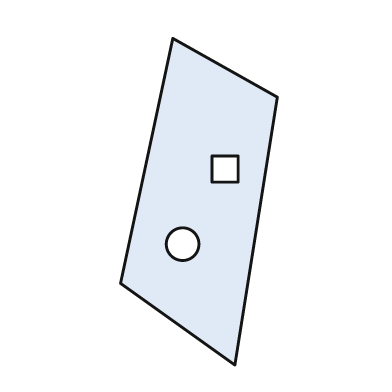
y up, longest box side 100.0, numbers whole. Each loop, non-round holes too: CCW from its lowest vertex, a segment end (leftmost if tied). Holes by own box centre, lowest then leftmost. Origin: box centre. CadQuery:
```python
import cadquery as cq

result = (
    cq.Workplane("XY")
    .moveTo(11.0, -50.0)
    .lineTo(24.0, 32.0)
    .lineTo(-8.0, 50.0)
    .lineTo(-24.0, -25.0)
    .close()
    .moveTo(-5.0, -13.0)
    .circle(5.0)
    .moveTo(4.0, 6.0)
    .lineTo(12.0, 6.0)
    .lineTo(12.0, 14.0)
    .lineTo(4.0, 14.0)
    .close()
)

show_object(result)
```